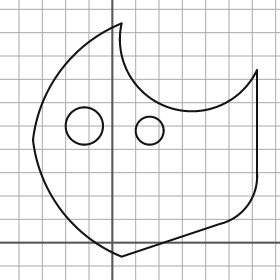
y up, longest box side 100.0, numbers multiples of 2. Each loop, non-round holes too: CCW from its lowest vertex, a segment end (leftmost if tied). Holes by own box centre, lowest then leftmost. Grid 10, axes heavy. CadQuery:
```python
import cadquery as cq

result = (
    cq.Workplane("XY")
    .moveTo(4.0, -6.0)
    .lineTo(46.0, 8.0)
    .threePointArc((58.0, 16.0), (62.0, 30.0))
    .lineTo(62.0, 74.0)
    .threePointArc((24.0, 58.0), (4.0, 94.0))
    .threePointArc((-22.0, 74.0), (-34.0, 44.0))
    .threePointArc((-22.0, 14.0), (4.0, -6.0))
    .close()
    .moveTo(16.0, 48.0)
    .circle(6.0)
    .moveTo(-12.0, 50.0)
    .circle(8.0)
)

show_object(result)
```